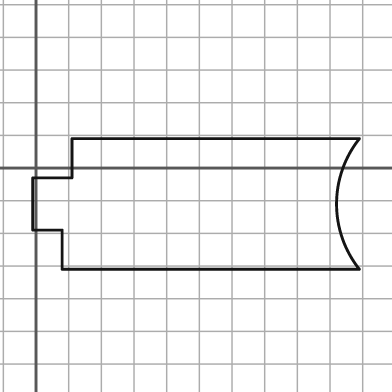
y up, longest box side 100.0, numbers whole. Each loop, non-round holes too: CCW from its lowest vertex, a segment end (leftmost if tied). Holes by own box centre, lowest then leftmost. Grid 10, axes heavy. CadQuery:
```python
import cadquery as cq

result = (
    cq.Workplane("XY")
    .moveTo(8.0, -31.0)
    .lineTo(99.0, -31.0)
    .threePointArc((92.0, -11.0), (99.0, 9.0))
    .lineTo(11.0, 9.0)
    .lineTo(11.0, -3.0)
    .lineTo(-1.0, -3.0)
    .lineTo(-1.0, -19.0)
    .lineTo(8.0, -19.0)
    .close()
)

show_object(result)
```